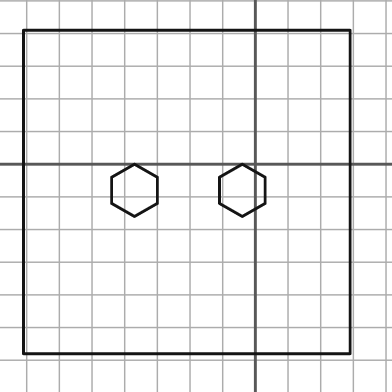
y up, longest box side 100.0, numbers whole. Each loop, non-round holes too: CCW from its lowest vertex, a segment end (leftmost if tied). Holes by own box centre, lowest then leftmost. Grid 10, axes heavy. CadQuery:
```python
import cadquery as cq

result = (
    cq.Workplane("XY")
    .moveTo(-71.0, -58.0)
    .lineTo(29.0, -58.0)
    .lineTo(29.0, 41.0)
    .lineTo(-71.0, 41.0)
    .close()
    .moveTo(-37.0, -16.0)
    .lineTo(-30.0, -12.0)
    .lineTo(-30.0, -4.0)
    .lineTo(-37.0, 0.0)
    .lineTo(-44.0, -4.0)
    .lineTo(-44.0, -12.0)
    .close()
    .moveTo(-4.0, -16.0)
    .lineTo(3.0, -12.0)
    .lineTo(3.0, -4.0)
    .lineTo(-4.0, 0.0)
    .lineTo(-11.0, -4.0)
    .lineTo(-11.0, -12.0)
    .close()
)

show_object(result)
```